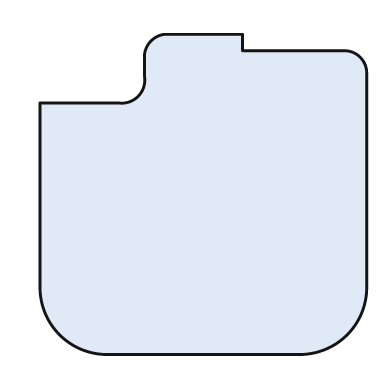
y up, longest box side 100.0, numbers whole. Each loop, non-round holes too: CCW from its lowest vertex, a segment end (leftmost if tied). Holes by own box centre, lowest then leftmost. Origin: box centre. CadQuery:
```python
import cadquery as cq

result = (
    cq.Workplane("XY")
    .moveTo(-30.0, -49.0)
    .lineTo(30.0, -49.0)
    .threePointArc((44.0, -43.0), (50.0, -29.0))
    .lineTo(50.0, 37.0)
    .threePointArc((48.0, 42.0), (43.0, 44.0))
    .lineTo(12.0, 44.0)
    .lineTo(12.0, 49.0)
    .lineTo(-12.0, 49.0)
    .threePointArc((-16.0, 47.0), (-18.0, 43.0))
    .lineTo(-18.0, 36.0)
    .threePointArc((-20.0, 30.0), (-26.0, 28.0))
    .lineTo(-50.0, 28.0)
    .lineTo(-50.0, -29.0)
    .threePointArc((-44.0, -43.0), (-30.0, -49.0))
    .close()
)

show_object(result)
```